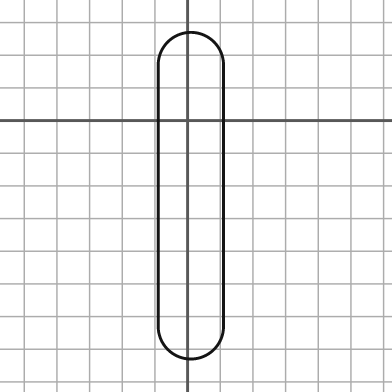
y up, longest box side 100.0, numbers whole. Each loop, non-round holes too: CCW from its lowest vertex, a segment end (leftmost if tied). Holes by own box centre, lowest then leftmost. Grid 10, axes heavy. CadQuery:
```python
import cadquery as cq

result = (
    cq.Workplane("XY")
    .moveTo(-9.0, -63.0)
    .threePointArc((1.0, -73.0), (11.0, -63.0))
    .lineTo(11.0, 17.0)
    .threePointArc((1.0, 27.0), (-9.0, 17.0))
    .close()
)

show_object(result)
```